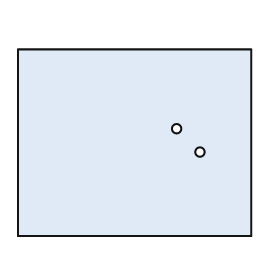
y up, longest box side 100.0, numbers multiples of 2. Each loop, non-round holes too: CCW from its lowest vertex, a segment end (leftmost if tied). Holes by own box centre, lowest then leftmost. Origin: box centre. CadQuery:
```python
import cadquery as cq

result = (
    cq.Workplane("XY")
    .moveTo(-50.0, -40.0)
    .lineTo(50.0, -40.0)
    .lineTo(50.0, 40.0)
    .lineTo(-50.0, 40.0)
    .close()
    .moveTo(28.0, -4.0)
    .circle(2.0)
    .moveTo(18.0, 6.0)
    .circle(2.0)
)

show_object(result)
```